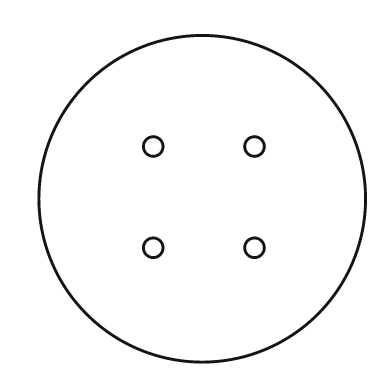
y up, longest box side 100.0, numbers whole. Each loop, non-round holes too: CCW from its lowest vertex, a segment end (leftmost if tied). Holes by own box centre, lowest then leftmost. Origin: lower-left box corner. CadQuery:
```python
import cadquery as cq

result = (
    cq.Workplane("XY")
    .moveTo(50.0, 50.0)
    .circle(50.0)
    .moveTo(35.0, 35.0)
    .circle(3.0)
    .moveTo(66.0, 35.0)
    .circle(3.0)
    .moveTo(35.0, 66.0)
    .circle(3.0)
    .moveTo(66.0, 66.0)
    .circle(3.0)
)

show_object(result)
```